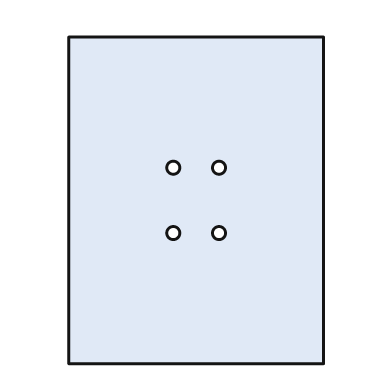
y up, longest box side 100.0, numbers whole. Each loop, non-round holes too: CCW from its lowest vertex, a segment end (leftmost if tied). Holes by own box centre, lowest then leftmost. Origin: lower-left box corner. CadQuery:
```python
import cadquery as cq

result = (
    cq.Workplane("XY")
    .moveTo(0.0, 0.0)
    .lineTo(78.0, 0.0)
    .lineTo(78.0, 100.0)
    .lineTo(0.0, 100.0)
    .close()
    .moveTo(32.0, 40.0)
    .circle(2.0)
    .moveTo(46.0, 40.0)
    .circle(2.0)
    .moveTo(32.0, 60.0)
    .circle(2.0)
    .moveTo(46.0, 60.0)
    .circle(2.0)
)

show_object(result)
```